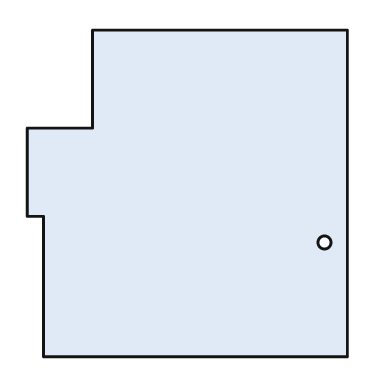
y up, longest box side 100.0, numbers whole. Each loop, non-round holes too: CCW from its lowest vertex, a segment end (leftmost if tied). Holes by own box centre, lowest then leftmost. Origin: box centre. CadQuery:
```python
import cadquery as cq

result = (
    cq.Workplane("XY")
    .moveTo(-44.0, -50.0)
    .lineTo(49.0, -50.0)
    .lineTo(49.0, 50.0)
    .lineTo(-29.0, 50.0)
    .lineTo(-29.0, 20.0)
    .lineTo(-49.0, 20.0)
    .lineTo(-49.0, -7.0)
    .lineTo(-44.0, -7.0)
    .close()
    .moveTo(42.0, -15.0)
    .circle(2.0)
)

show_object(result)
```